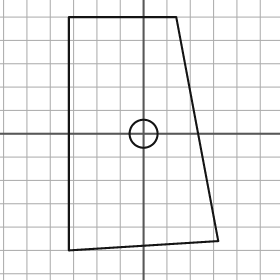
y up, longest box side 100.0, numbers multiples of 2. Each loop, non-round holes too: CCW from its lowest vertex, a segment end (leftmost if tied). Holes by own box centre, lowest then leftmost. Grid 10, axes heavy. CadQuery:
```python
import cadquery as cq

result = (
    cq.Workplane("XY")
    .moveTo(-32.0, -50.0)
    .lineTo(32.0, -46.0)
    .lineTo(14.0, 50.0)
    .lineTo(-32.0, 50.0)
    .close()
    .moveTo(0.0, 0.0)
    .circle(6.0)
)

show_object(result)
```